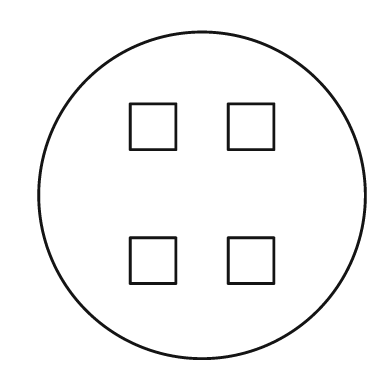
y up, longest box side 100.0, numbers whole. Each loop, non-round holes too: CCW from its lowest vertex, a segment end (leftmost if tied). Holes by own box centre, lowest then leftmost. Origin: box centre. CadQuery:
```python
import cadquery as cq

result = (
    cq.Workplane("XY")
    .moveTo(0.0, 0.0)
    .circle(50.0)
    .moveTo(-22.0, -27.0)
    .lineTo(-8.0, -27.0)
    .lineTo(-8.0, -13.0)
    .lineTo(-22.0, -13.0)
    .close()
    .moveTo(8.0, -27.0)
    .lineTo(22.0, -27.0)
    .lineTo(22.0, -13.0)
    .lineTo(8.0, -13.0)
    .close()
    .moveTo(-22.0, 14.0)
    .lineTo(-8.0, 14.0)
    .lineTo(-8.0, 28.0)
    .lineTo(-22.0, 28.0)
    .close()
    .moveTo(8.0, 14.0)
    .lineTo(22.0, 14.0)
    .lineTo(22.0, 28.0)
    .lineTo(8.0, 28.0)
    .close()
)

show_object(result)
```